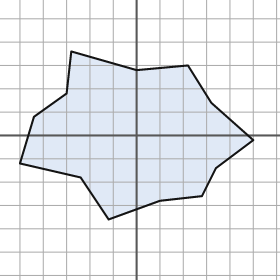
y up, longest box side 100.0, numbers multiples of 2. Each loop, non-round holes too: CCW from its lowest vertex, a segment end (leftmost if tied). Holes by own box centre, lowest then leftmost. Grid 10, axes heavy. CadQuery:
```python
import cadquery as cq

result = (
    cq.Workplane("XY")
    .moveTo(-12.0, -36.0)
    .lineTo(10.0, -28.0)
    .lineTo(28.0, -26.0)
    .lineTo(34.0, -14.0)
    .lineTo(50.0, -2.0)
    .lineTo(32.0, 14.0)
    .lineTo(22.0, 30.0)
    .lineTo(0.0, 28.0)
    .lineTo(-28.0, 36.0)
    .lineTo(-30.0, 18.0)
    .lineTo(-44.0, 8.0)
    .lineTo(-50.0, -12.0)
    .lineTo(-24.0, -18.0)
    .close()
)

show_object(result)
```